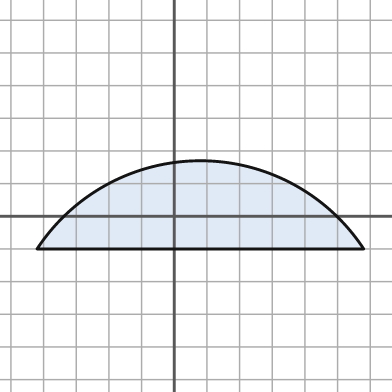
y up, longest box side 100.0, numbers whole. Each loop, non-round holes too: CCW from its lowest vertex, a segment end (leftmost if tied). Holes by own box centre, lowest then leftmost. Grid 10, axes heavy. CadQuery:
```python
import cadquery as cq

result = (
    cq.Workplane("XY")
    .moveTo(-42.0, -10.0)
    .lineTo(58.0, -10.0)
    .threePointArc((8.0, 17.0), (-42.0, -10.0))
    .close()
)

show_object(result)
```